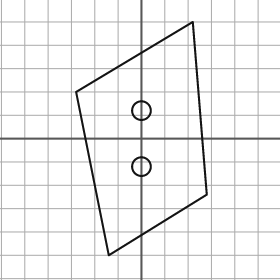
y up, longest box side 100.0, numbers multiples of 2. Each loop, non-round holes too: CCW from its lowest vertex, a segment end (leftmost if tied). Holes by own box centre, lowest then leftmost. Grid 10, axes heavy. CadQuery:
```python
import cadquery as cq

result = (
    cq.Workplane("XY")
    .moveTo(-14.0, -50.0)
    .lineTo(28.0, -24.0)
    .lineTo(22.0, 50.0)
    .lineTo(-28.0, 20.0)
    .close()
    .moveTo(0.0, -12.0)
    .circle(4.0)
    .moveTo(0.0, 12.0)
    .circle(4.0)
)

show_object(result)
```